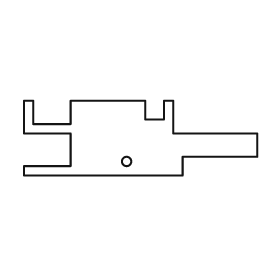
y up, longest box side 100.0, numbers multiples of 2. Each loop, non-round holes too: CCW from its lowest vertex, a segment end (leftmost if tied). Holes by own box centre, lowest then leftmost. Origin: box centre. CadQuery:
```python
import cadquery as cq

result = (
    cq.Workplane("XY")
    .moveTo(-50.0, -16.0)
    .lineTo(18.0, -16.0)
    .lineTo(18.0, -8.0)
    .lineTo(50.0, -8.0)
    .lineTo(50.0, 2.0)
    .lineTo(14.0, 2.0)
    .lineTo(14.0, 16.0)
    .lineTo(10.0, 16.0)
    .lineTo(10.0, 8.0)
    .lineTo(2.0, 8.0)
    .lineTo(2.0, 16.0)
    .lineTo(-30.0, 16.0)
    .lineTo(-30.0, 6.0)
    .lineTo(-46.0, 6.0)
    .lineTo(-46.0, 16.0)
    .lineTo(-50.0, 16.0)
    .lineTo(-50.0, 2.0)
    .lineTo(-30.0, 2.0)
    .lineTo(-30.0, -12.0)
    .lineTo(-50.0, -12.0)
    .close()
    .moveTo(-6.0, -10.0)
    .circle(2.0)
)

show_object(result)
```